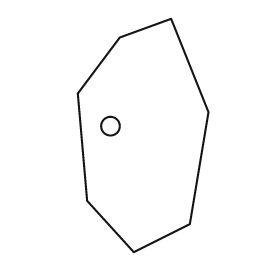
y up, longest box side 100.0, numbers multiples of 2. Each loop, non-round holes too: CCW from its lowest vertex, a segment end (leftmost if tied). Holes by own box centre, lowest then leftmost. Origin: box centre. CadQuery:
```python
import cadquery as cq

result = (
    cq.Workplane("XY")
    .moveTo(-4.0, -50.0)
    .lineTo(20.0, -38.0)
    .lineTo(28.0, 10.0)
    .lineTo(12.0, 50.0)
    .lineTo(-10.0, 42.0)
    .lineTo(-28.0, 18.0)
    .lineTo(-24.0, -28.0)
    .close()
    .moveTo(-14.0, 4.0)
    .circle(4.0)
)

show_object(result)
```